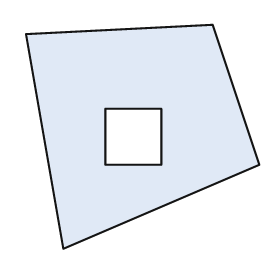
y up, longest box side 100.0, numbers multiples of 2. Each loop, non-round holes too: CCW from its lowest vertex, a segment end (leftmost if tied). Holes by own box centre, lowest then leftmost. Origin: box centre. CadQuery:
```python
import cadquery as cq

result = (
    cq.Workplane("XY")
    .moveTo(-34.0, -48.0)
    .lineTo(50.0, -12.0)
    .lineTo(30.0, 48.0)
    .lineTo(-50.0, 44.0)
    .close()
    .moveTo(-16.0, -12.0)
    .lineTo(8.0, -12.0)
    .lineTo(8.0, 12.0)
    .lineTo(-16.0, 12.0)
    .close()
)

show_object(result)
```